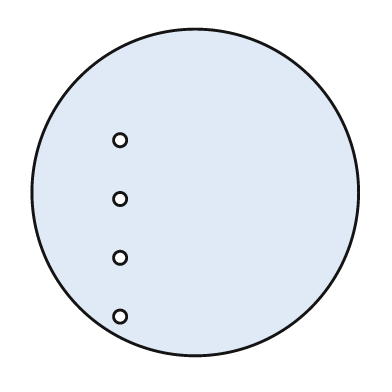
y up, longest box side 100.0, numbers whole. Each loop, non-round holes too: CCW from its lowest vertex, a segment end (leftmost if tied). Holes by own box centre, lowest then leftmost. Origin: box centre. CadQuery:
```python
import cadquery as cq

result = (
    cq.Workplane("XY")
    .moveTo(0.0, 0.0)
    .circle(50.0)
    .moveTo(-23.0, -38.0)
    .circle(2.0)
    .moveTo(-23.0, -20.0)
    .circle(2.0)
    .moveTo(-23.0, -2.0)
    .circle(2.0)
    .moveTo(-23.0, 16.0)
    .circle(2.0)
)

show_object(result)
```